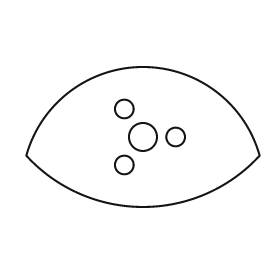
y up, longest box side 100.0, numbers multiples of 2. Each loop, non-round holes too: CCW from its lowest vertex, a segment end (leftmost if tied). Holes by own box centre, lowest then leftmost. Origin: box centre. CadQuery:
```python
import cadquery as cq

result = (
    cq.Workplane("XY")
    .moveTo(-50.0, -8.0)
    .threePointArc((0.0, -30.0), (50.0, -8.0))
    .threePointArc((0.0, 30.0), (-50.0, -8.0))
    .close()
    .moveTo(-8.0, -12.0)
    .circle(4.0)
    .moveTo(0.0, 0.0)
    .circle(6.0)
    .moveTo(14.0, 0.0)
    .circle(4.0)
    .moveTo(-8.0, 12.0)
    .circle(4.0)
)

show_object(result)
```